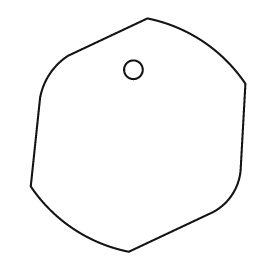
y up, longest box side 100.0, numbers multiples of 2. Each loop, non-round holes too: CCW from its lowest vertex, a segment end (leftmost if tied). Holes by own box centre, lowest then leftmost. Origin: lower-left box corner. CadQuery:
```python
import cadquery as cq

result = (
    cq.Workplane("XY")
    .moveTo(42.0, 0.0)
    .lineTo(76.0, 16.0)
    .threePointArc((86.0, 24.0), (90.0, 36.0))
    .lineTo(92.0, 72.0)
    .threePointArc((74.0, 90.0), (50.0, 100.0))
    .lineTo(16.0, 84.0)
    .threePointArc((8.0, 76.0), (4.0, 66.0))
    .lineTo(0.0, 28.0)
    .threePointArc((18.0, 10.0), (42.0, 0.0))
    .close()
    .moveTo(44.0, 78.0)
    .circle(4.0)
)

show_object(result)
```